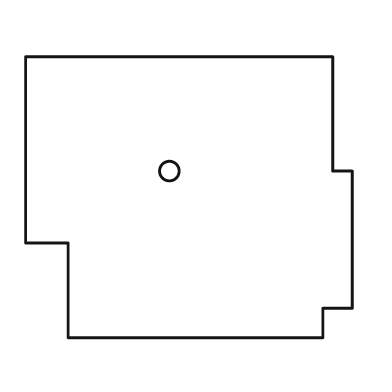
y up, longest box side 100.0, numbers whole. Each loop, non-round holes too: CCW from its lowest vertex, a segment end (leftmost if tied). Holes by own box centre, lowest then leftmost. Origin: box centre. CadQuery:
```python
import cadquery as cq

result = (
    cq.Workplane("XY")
    .moveTo(-37.0, -43.0)
    .lineTo(41.0, -43.0)
    .lineTo(41.0, -34.0)
    .lineTo(50.0, -34.0)
    .lineTo(50.0, 8.0)
    .lineTo(44.0, 8.0)
    .lineTo(44.0, 43.0)
    .lineTo(-50.0, 43.0)
    .lineTo(-50.0, -14.0)
    .lineTo(-37.0, -14.0)
    .close()
    .moveTo(-6.0, 8.0)
    .circle(3.0)
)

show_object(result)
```